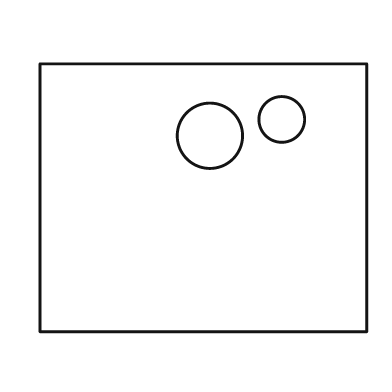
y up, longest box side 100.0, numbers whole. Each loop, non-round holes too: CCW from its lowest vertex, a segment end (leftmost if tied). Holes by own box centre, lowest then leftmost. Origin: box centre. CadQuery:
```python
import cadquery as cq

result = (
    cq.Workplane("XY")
    .moveTo(-50.0, -41.0)
    .lineTo(50.0, -41.0)
    .lineTo(50.0, 41.0)
    .lineTo(-50.0, 41.0)
    .close()
    .moveTo(2.0, 19.0)
    .circle(10.0)
    .moveTo(24.0, 24.0)
    .circle(7.0)
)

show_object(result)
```